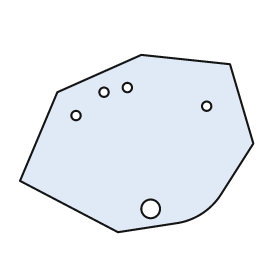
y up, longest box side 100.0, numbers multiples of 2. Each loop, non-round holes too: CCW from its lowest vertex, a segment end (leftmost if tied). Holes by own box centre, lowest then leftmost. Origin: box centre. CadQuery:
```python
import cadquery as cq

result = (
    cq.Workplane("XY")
    .moveTo(-8.0, -38.0)
    .lineTo(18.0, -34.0)
    .threePointArc((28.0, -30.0), (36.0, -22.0))
    .lineTo(50.0, 0.0)
    .lineTo(40.0, 34.0)
    .lineTo(2.0, 38.0)
    .lineTo(-34.0, 22.0)
    .lineTo(-50.0, -16.0)
    .close()
    .moveTo(6.0, -28.0)
    .circle(4.0)
    .moveTo(-26.0, 12.0)
    .circle(2.0)
    .moveTo(30.0, 16.0)
    .circle(2.0)
    .moveTo(-14.0, 22.0)
    .circle(2.0)
    .moveTo(-4.0, 24.0)
    .circle(2.0)
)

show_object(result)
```